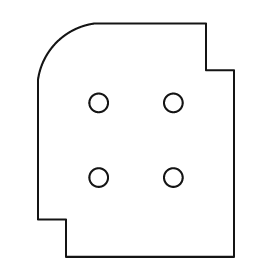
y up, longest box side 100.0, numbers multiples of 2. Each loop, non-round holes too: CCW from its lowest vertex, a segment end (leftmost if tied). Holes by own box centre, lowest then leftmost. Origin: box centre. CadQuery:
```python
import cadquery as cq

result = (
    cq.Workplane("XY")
    .moveTo(-30.0, -50.0)
    .lineTo(42.0, -50.0)
    .lineTo(42.0, 30.0)
    .lineTo(30.0, 30.0)
    .lineTo(30.0, 50.0)
    .lineTo(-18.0, 50.0)
    .threePointArc((-34.0, 42.0), (-42.0, 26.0))
    .lineTo(-42.0, -34.0)
    .lineTo(-30.0, -34.0)
    .close()
    .moveTo(-16.0, -16.0)
    .circle(4.0)
    .moveTo(16.0, -16.0)
    .circle(4.0)
    .moveTo(-16.0, 16.0)
    .circle(4.0)
    .moveTo(16.0, 16.0)
    .circle(4.0)
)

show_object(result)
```